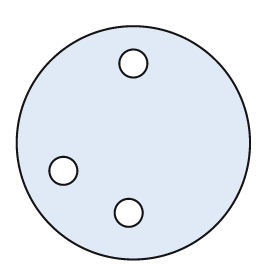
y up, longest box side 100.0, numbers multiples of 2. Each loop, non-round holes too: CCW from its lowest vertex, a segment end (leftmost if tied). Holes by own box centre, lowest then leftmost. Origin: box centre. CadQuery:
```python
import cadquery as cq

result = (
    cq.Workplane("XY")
    .moveTo(0.0, 0.0)
    .circle(50.0)
    .moveTo(-2.0, -30.0)
    .circle(6.0)
    .moveTo(-30.0, -12.0)
    .circle(6.0)
    .moveTo(0.0, 34.0)
    .circle(6.0)
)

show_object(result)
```